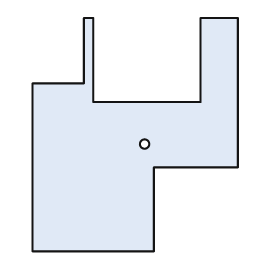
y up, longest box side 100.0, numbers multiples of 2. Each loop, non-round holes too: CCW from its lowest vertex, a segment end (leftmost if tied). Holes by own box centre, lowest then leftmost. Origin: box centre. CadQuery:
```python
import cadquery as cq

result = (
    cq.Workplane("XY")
    .moveTo(-44.0, -50.0)
    .lineTo(8.0, -50.0)
    .lineTo(8.0, -14.0)
    .lineTo(44.0, -14.0)
    .lineTo(44.0, 50.0)
    .lineTo(28.0, 50.0)
    .lineTo(28.0, 14.0)
    .lineTo(-18.0, 14.0)
    .lineTo(-18.0, 50.0)
    .lineTo(-22.0, 50.0)
    .lineTo(-22.0, 22.0)
    .lineTo(-44.0, 22.0)
    .close()
    .moveTo(4.0, -4.0)
    .circle(2.0)
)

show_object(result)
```